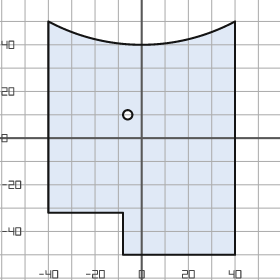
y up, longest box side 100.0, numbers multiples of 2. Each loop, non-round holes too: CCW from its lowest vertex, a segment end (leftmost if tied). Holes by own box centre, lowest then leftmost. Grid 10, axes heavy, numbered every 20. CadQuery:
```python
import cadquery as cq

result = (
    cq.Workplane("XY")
    .moveTo(-8.0, -50.0)
    .lineTo(40.0, -50.0)
    .lineTo(40.0, 50.0)
    .threePointArc((0.0, 40.0), (-40.0, 50.0))
    .lineTo(-40.0, -32.0)
    .lineTo(-8.0, -32.0)
    .close()
    .moveTo(-6.0, 10.0)
    .circle(2.0)
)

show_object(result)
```